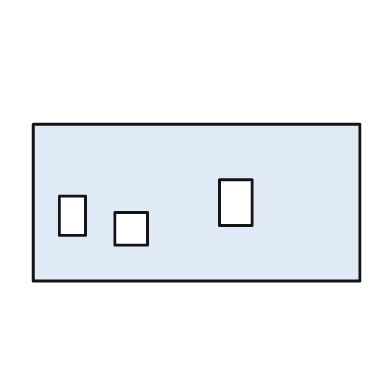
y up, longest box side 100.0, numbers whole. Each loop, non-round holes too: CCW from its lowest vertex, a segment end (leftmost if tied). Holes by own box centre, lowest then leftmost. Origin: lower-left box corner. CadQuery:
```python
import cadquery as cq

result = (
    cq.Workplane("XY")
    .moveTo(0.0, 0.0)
    .lineTo(100.0, 0.0)
    .lineTo(100.0, 48.0)
    .lineTo(0.0, 48.0)
    .close()
    .moveTo(25.0, 11.0)
    .lineTo(35.0, 11.0)
    .lineTo(35.0, 21.0)
    .lineTo(25.0, 21.0)
    .close()
    .moveTo(8.0, 14.0)
    .lineTo(16.0, 14.0)
    .lineTo(16.0, 26.0)
    .lineTo(8.0, 26.0)
    .close()
    .moveTo(57.0, 17.0)
    .lineTo(67.0, 17.0)
    .lineTo(67.0, 31.0)
    .lineTo(57.0, 31.0)
    .close()
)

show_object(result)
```